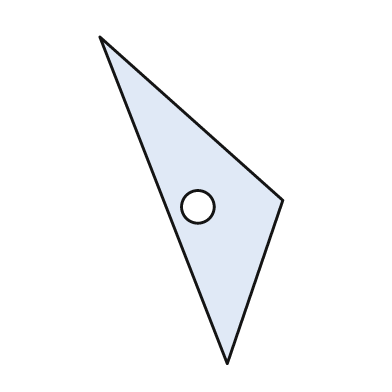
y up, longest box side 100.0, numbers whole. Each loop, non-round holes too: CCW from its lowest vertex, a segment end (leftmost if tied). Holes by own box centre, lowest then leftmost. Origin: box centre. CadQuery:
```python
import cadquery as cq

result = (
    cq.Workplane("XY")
    .moveTo(11.0, -50.0)
    .lineTo(28.0, 0.0)
    .lineTo(-28.0, 50.0)
    .close()
    .moveTo(2.0, -2.0)
    .circle(5.0)
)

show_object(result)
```